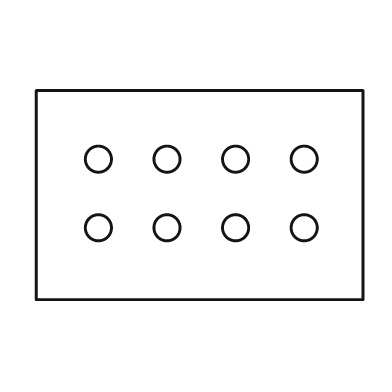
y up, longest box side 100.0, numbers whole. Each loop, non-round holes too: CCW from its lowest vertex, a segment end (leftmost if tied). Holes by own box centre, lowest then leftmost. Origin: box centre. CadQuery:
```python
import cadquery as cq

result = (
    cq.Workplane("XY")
    .moveTo(-50.0, -32.0)
    .lineTo(50.0, -32.0)
    .lineTo(50.0, 32.0)
    .lineTo(-50.0, 32.0)
    .close()
    .moveTo(-31.0, -10.0)
    .circle(4.0)
    .moveTo(-10.0, -10.0)
    .circle(4.0)
    .moveTo(11.0, -10.0)
    .circle(4.0)
    .moveTo(32.0, -10.0)
    .circle(4.0)
    .moveTo(-31.0, 11.0)
    .circle(4.0)
    .moveTo(-10.0, 11.0)
    .circle(4.0)
    .moveTo(11.0, 11.0)
    .circle(4.0)
    .moveTo(32.0, 11.0)
    .circle(4.0)
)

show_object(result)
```